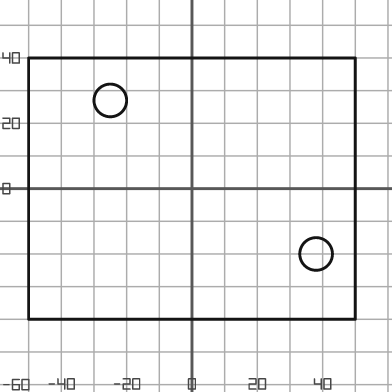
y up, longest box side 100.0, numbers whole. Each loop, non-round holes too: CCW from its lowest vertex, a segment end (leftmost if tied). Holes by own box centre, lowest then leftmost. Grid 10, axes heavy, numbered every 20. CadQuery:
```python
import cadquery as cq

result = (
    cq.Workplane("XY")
    .moveTo(-50.0, -40.0)
    .lineTo(50.0, -40.0)
    .lineTo(50.0, 40.0)
    .lineTo(-50.0, 40.0)
    .close()
    .moveTo(38.0, -20.0)
    .circle(5.0)
    .moveTo(-25.0, 27.0)
    .circle(5.0)
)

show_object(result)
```